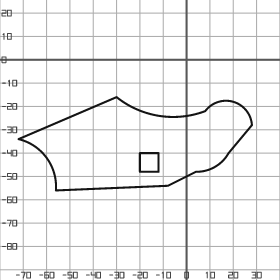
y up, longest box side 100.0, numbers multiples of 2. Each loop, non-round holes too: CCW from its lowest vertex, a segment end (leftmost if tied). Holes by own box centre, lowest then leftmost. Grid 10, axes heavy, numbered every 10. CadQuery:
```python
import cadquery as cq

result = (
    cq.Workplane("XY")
    .moveTo(-56.0, -56.0)
    .lineTo(-8.0, -54.0)
    .lineTo(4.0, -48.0)
    .threePointArc((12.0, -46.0), (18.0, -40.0))
    .lineTo(28.0, -28.0)
    .threePointArc((20.0, -18.0), (8.0, -22.0))
    .threePointArc((-12.0, -24.0), (-30.0, -16.0))
    .lineTo(-72.0, -34.0)
    .threePointArc((-60.0, -42.0), (-56.0, -56.0))
    .close()
    .moveTo(-20.0, -48.0)
    .lineTo(-12.0, -48.0)
    .lineTo(-12.0, -40.0)
    .lineTo(-20.0, -40.0)
    .close()
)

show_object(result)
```